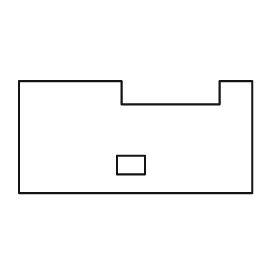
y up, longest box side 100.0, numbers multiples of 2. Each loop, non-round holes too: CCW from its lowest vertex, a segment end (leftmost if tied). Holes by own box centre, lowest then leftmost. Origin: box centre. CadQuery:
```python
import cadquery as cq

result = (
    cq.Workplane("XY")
    .moveTo(-50.0, -24.0)
    .lineTo(50.0, -24.0)
    .lineTo(50.0, 24.0)
    .lineTo(36.0, 24.0)
    .lineTo(36.0, 14.0)
    .lineTo(-6.0, 14.0)
    .lineTo(-6.0, 24.0)
    .lineTo(-50.0, 24.0)
    .close()
    .moveTo(-8.0, -16.0)
    .lineTo(4.0, -16.0)
    .lineTo(4.0, -8.0)
    .lineTo(-8.0, -8.0)
    .close()
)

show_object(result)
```